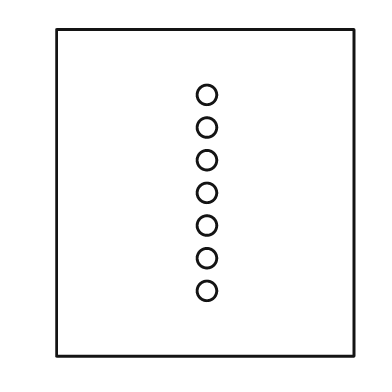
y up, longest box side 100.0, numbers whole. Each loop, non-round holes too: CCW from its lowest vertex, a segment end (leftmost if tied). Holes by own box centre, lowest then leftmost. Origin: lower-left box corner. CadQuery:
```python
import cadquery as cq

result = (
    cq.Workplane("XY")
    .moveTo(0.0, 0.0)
    .lineTo(91.0, 0.0)
    .lineTo(91.0, 100.0)
    .lineTo(0.0, 100.0)
    .close()
    .moveTo(46.0, 20.0)
    .circle(3.0)
    .moveTo(46.0, 30.0)
    .circle(3.0)
    .moveTo(46.0, 40.0)
    .circle(3.0)
    .moveTo(46.0, 50.0)
    .circle(3.0)
    .moveTo(46.0, 60.0)
    .circle(3.0)
    .moveTo(46.0, 70.0)
    .circle(3.0)
    .moveTo(46.0, 80.0)
    .circle(3.0)
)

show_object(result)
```